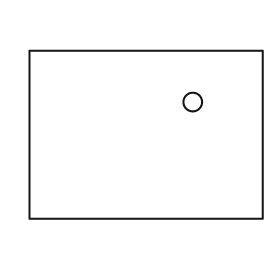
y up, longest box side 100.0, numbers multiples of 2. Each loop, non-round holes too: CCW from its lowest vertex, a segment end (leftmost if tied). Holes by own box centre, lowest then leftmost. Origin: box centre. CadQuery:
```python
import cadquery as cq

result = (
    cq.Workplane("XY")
    .moveTo(-50.0, -36.0)
    .lineTo(50.0, -36.0)
    .lineTo(50.0, 36.0)
    .lineTo(-50.0, 36.0)
    .close()
    .moveTo(20.0, 14.0)
    .circle(4.0)
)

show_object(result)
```